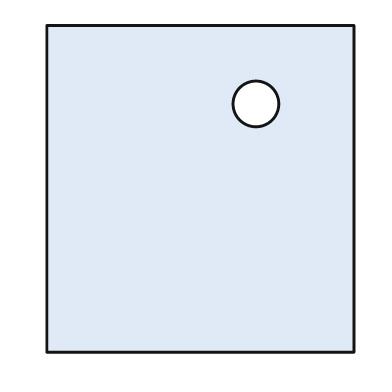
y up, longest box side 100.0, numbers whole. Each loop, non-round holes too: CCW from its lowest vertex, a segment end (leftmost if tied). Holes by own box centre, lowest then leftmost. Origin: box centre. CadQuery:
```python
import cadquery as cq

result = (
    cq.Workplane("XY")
    .moveTo(-47.0, -50.0)
    .lineTo(47.0, -50.0)
    .lineTo(47.0, 50.0)
    .lineTo(-47.0, 50.0)
    .close()
    .moveTo(17.0, 26.0)
    .circle(7.0)
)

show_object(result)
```